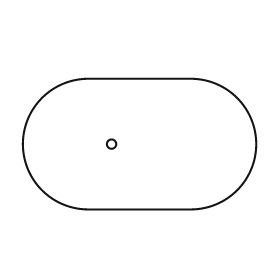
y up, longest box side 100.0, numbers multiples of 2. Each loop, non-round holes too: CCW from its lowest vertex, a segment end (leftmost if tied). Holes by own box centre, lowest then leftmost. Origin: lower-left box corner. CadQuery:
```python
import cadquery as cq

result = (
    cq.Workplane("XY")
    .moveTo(28.0, 0.0)
    .lineTo(72.0, 0.0)
    .threePointArc((100.0, 28.0), (72.0, 56.0))
    .lineTo(28.0, 56.0)
    .threePointArc((0.0, 28.0), (28.0, 0.0))
    .close()
    .moveTo(38.0, 28.0)
    .circle(2.0)
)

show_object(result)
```